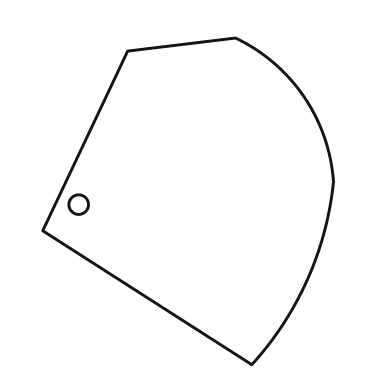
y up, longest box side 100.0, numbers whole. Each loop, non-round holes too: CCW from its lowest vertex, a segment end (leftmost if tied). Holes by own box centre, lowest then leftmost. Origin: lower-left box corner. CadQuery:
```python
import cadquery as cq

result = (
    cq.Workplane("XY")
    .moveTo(64.0, 0.0)
    .threePointArc((81.0, 26.0), (89.0, 56.0))
    .threePointArc((80.0, 82.0), (59.0, 100.0))
    .lineTo(26.0, 96.0)
    .lineTo(0.0, 41.0)
    .close()
    .moveTo(11.0, 49.0)
    .circle(3.0)
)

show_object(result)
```